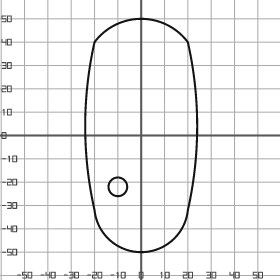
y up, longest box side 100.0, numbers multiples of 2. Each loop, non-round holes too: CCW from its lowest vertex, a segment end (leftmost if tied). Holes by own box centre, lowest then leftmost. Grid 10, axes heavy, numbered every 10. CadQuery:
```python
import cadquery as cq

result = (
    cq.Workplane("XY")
    .moveTo(-20.0, -32.0)
    .threePointArc((0.0, -50.0), (20.0, -32.0))
    .threePointArc((24.0, 4.0), (20.0, 40.0))
    .threePointArc((0.0, 50.0), (-20.0, 40.0))
    .threePointArc((-24.0, 4.0), (-20.0, -32.0))
    .close()
    .moveTo(-10.0, -22.0)
    .circle(4.0)
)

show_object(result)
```